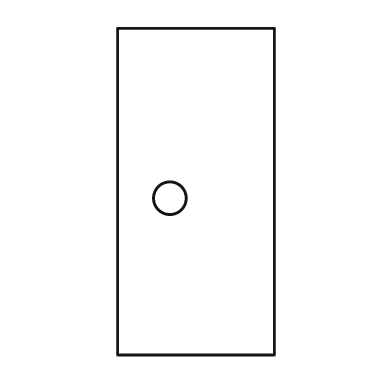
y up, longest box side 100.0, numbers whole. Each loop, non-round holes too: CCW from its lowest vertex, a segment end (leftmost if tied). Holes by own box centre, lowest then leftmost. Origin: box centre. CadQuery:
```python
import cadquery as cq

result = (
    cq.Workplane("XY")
    .moveTo(-24.0, -50.0)
    .lineTo(24.0, -50.0)
    .lineTo(24.0, 50.0)
    .lineTo(-24.0, 50.0)
    .close()
    .moveTo(-8.0, -2.0)
    .circle(5.0)
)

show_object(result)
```